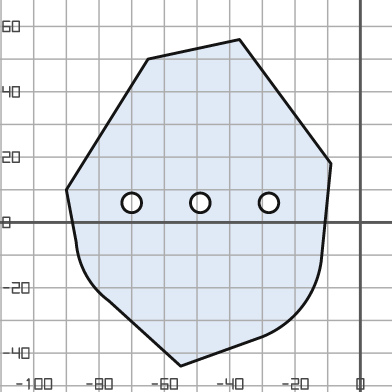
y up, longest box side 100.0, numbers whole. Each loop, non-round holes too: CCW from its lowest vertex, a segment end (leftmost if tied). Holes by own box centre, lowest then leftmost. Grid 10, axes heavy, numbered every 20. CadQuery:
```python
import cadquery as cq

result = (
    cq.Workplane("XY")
    .moveTo(-55.0, -44.0)
    .lineTo(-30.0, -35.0)
    .threePointArc((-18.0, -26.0), (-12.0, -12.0))
    .lineTo(-9.0, 18.0)
    .lineTo(-37.0, 56.0)
    .lineTo(-65.0, 50.0)
    .lineTo(-90.0, 10.0)
    .lineTo(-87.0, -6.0)
    .threePointArc((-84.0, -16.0), (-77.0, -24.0))
    .close()
    .moveTo(-70.0, 6.0)
    .circle(3.0)
    .moveTo(-49.0, 6.0)
    .circle(3.0)
    .moveTo(-28.0, 6.0)
    .circle(3.0)
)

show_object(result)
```